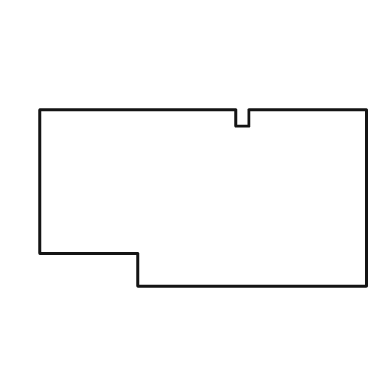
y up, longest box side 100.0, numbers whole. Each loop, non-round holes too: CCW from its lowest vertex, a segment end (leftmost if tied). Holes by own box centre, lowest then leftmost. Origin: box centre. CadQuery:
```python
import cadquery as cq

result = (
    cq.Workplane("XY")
    .moveTo(-20.0, -27.0)
    .lineTo(50.0, -27.0)
    .lineTo(50.0, 27.0)
    .lineTo(14.0, 27.0)
    .lineTo(14.0, 22.0)
    .lineTo(10.0, 22.0)
    .lineTo(10.0, 27.0)
    .lineTo(-50.0, 27.0)
    .lineTo(-50.0, -17.0)
    .lineTo(-20.0, -17.0)
    .close()
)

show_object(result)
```